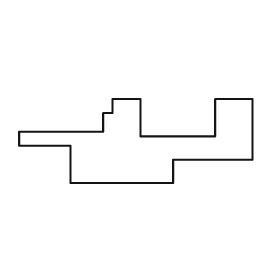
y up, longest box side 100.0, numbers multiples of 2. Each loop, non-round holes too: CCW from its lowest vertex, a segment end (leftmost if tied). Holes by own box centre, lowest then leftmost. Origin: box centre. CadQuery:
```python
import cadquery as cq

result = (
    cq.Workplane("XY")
    .moveTo(-28.0, -18.0)
    .lineTo(16.0, -18.0)
    .lineTo(16.0, -8.0)
    .lineTo(50.0, -8.0)
    .lineTo(50.0, 18.0)
    .lineTo(34.0, 18.0)
    .lineTo(34.0, 2.0)
    .lineTo(2.0, 2.0)
    .lineTo(2.0, 18.0)
    .lineTo(-10.0, 18.0)
    .lineTo(-10.0, 12.0)
    .lineTo(-14.0, 12.0)
    .lineTo(-14.0, 4.0)
    .lineTo(-50.0, 4.0)
    .lineTo(-50.0, -2.0)
    .lineTo(-28.0, -2.0)
    .close()
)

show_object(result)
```